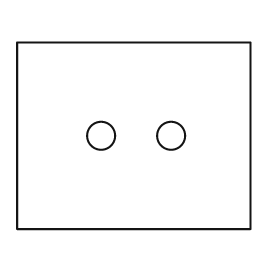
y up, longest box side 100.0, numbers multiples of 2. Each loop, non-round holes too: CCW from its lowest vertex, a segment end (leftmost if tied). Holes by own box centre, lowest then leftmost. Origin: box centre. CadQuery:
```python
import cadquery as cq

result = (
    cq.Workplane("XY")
    .moveTo(-50.0, -40.0)
    .lineTo(50.0, -40.0)
    .lineTo(50.0, 40.0)
    .lineTo(-50.0, 40.0)
    .close()
    .moveTo(-14.0, 0.0)
    .circle(6.0)
    .moveTo(16.0, 0.0)
    .circle(6.0)
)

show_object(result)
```